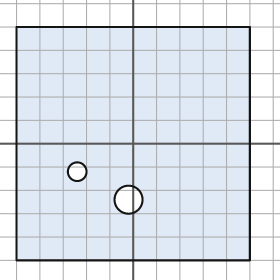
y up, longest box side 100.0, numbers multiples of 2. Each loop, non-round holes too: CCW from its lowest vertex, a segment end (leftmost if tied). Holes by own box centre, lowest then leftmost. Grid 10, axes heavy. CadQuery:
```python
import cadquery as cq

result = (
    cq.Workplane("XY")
    .moveTo(-50.0, -50.0)
    .lineTo(50.0, -50.0)
    .lineTo(50.0, 50.0)
    .lineTo(-50.0, 50.0)
    .close()
    .moveTo(-2.0, -24.0)
    .circle(6.0)
    .moveTo(-24.0, -12.0)
    .circle(4.0)
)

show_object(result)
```